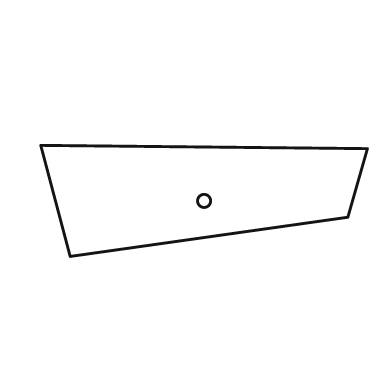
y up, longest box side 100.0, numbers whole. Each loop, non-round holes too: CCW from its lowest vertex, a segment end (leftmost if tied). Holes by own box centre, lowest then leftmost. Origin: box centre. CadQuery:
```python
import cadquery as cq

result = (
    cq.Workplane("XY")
    .moveTo(-41.0, -17.0)
    .lineTo(44.0, -5.0)
    .lineTo(50.0, 16.0)
    .lineTo(-50.0, 17.0)
    .close()
    .moveTo(0.0, 0.0)
    .circle(2.0)
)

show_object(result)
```